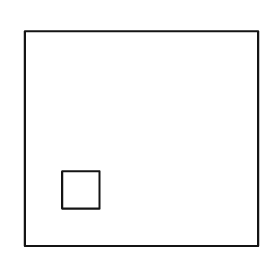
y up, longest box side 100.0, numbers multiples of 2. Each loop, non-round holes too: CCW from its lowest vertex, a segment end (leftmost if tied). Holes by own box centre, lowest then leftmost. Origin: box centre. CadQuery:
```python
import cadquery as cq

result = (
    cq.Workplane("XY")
    .moveTo(-50.0, -46.0)
    .lineTo(50.0, -46.0)
    .lineTo(50.0, 46.0)
    .lineTo(-50.0, 46.0)
    .close()
    .moveTo(-34.0, -30.0)
    .lineTo(-18.0, -30.0)
    .lineTo(-18.0, -14.0)
    .lineTo(-34.0, -14.0)
    .close()
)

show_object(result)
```